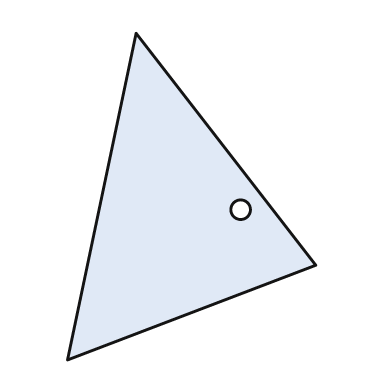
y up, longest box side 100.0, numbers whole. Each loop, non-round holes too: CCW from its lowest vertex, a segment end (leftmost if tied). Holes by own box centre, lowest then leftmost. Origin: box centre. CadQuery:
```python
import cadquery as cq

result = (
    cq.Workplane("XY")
    .moveTo(-38.0, -50.0)
    .lineTo(38.0, -21.0)
    .lineTo(-17.0, 50.0)
    .close()
    .moveTo(15.0, -4.0)
    .circle(3.0)
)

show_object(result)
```